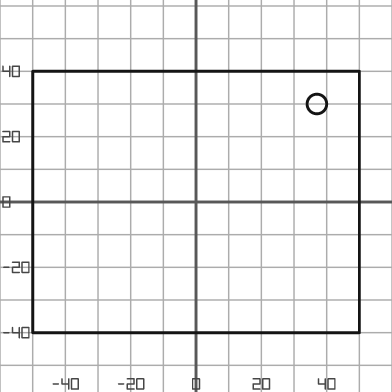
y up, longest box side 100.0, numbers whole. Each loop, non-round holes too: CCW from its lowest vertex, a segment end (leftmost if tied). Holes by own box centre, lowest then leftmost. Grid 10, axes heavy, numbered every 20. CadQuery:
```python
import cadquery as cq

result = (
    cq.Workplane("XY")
    .moveTo(-50.0, -40.0)
    .lineTo(50.0, -40.0)
    .lineTo(50.0, 40.0)
    .lineTo(-50.0, 40.0)
    .close()
    .moveTo(37.0, 30.0)
    .circle(3.0)
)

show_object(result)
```